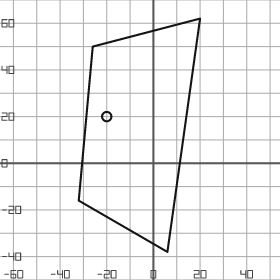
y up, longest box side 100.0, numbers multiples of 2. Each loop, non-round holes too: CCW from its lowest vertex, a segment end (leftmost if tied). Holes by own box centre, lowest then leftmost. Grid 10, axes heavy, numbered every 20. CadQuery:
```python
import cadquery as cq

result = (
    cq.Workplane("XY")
    .moveTo(6.0, -38.0)
    .lineTo(20.0, 62.0)
    .lineTo(-26.0, 50.0)
    .lineTo(-32.0, -16.0)
    .close()
    .moveTo(-20.0, 20.0)
    .circle(2.0)
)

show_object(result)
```